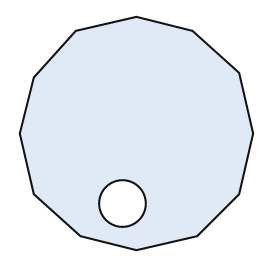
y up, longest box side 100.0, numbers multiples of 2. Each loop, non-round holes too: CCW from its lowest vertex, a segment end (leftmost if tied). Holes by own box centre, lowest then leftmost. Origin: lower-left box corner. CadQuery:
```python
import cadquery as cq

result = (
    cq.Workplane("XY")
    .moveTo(50.0, 0.0)
    .lineTo(76.0, 6.0)
    .lineTo(94.0, 24.0)
    .lineTo(100.0, 50.0)
    .lineTo(94.0, 76.0)
    .lineTo(74.0, 94.0)
    .lineTo(50.0, 100.0)
    .lineTo(24.0, 94.0)
    .lineTo(6.0, 74.0)
    .lineTo(0.0, 50.0)
    .lineTo(6.0, 24.0)
    .lineTo(26.0, 6.0)
    .close()
    .moveTo(44.0, 20.0)
    .circle(10.0)
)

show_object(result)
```